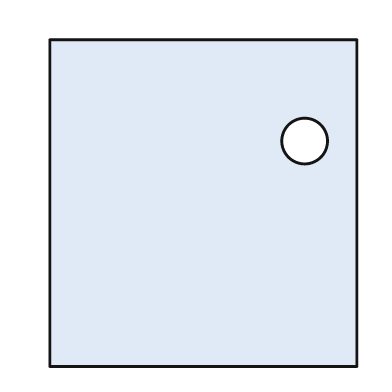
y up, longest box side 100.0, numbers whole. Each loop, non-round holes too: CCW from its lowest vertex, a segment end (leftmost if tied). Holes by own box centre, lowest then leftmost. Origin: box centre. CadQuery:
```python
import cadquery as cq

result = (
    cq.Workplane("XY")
    .moveTo(-47.0, -50.0)
    .lineTo(47.0, -50.0)
    .lineTo(47.0, 50.0)
    .lineTo(-47.0, 50.0)
    .close()
    .moveTo(31.0, 19.0)
    .circle(7.0)
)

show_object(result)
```